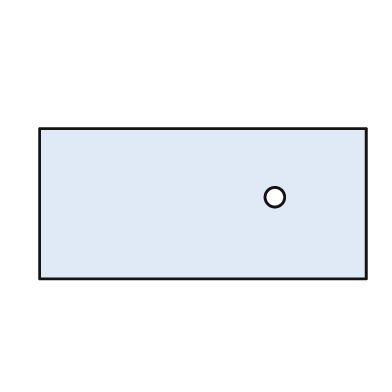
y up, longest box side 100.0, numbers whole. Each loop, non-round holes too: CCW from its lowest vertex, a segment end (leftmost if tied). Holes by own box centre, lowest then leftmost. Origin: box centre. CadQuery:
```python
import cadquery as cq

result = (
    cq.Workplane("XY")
    .moveTo(-50.0, -23.0)
    .lineTo(50.0, -23.0)
    .lineTo(50.0, 23.0)
    .lineTo(-50.0, 23.0)
    .close()
    .moveTo(22.0, 2.0)
    .circle(3.0)
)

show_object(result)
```